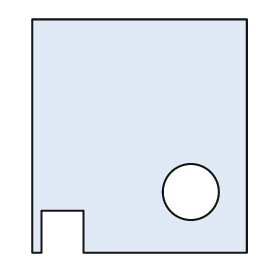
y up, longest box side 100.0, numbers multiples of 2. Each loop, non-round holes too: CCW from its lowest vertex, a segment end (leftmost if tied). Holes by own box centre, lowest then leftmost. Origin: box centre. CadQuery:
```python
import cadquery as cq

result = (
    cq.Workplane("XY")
    .moveTo(-46.0, -50.0)
    .lineTo(-42.0, -50.0)
    .lineTo(-42.0, -32.0)
    .lineTo(-24.0, -32.0)
    .lineTo(-24.0, -50.0)
    .lineTo(46.0, -50.0)
    .lineTo(46.0, 50.0)
    .lineTo(-46.0, 50.0)
    .close()
    .moveTo(22.0, -24.0)
    .circle(12.0)
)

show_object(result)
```